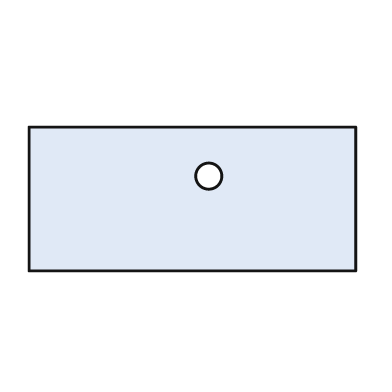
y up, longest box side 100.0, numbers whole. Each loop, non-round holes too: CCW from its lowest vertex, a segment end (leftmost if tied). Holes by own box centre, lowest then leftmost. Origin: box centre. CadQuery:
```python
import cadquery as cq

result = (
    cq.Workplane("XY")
    .moveTo(-50.0, -22.0)
    .lineTo(50.0, -22.0)
    .lineTo(50.0, 22.0)
    .lineTo(-50.0, 22.0)
    .close()
    .moveTo(5.0, 7.0)
    .circle(4.0)
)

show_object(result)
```